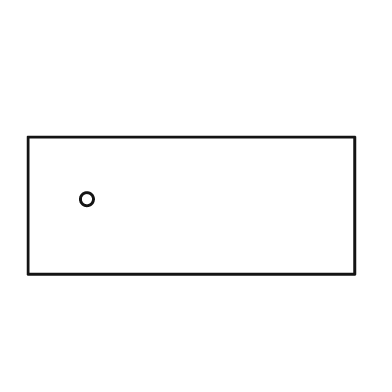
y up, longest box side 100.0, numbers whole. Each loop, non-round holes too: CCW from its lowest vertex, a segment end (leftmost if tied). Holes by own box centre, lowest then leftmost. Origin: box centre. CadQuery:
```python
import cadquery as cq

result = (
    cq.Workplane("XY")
    .moveTo(-50.0, -21.0)
    .lineTo(50.0, -21.0)
    .lineTo(50.0, 21.0)
    .lineTo(-50.0, 21.0)
    .close()
    .moveTo(-32.0, 2.0)
    .circle(2.0)
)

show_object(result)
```